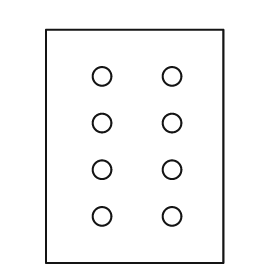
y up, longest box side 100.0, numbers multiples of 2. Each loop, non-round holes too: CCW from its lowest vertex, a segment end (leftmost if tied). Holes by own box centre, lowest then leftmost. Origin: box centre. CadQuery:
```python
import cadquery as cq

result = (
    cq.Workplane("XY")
    .moveTo(-38.0, -50.0)
    .lineTo(38.0, -50.0)
    .lineTo(38.0, 50.0)
    .lineTo(-38.0, 50.0)
    .close()
    .moveTo(-14.0, -30.0)
    .circle(4.0)
    .moveTo(16.0, -30.0)
    .circle(4.0)
    .moveTo(-14.0, -10.0)
    .circle(4.0)
    .moveTo(16.0, -10.0)
    .circle(4.0)
    .moveTo(-14.0, 10.0)
    .circle(4.0)
    .moveTo(16.0, 10.0)
    .circle(4.0)
    .moveTo(-14.0, 30.0)
    .circle(4.0)
    .moveTo(16.0, 30.0)
    .circle(4.0)
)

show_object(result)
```